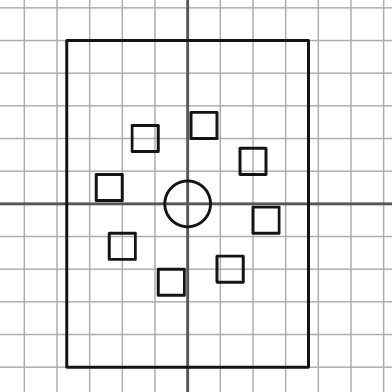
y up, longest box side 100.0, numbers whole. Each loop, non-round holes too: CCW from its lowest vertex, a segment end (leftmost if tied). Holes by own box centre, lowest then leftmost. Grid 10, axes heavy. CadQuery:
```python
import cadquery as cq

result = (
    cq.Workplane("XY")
    .moveTo(-37.0, -50.0)
    .lineTo(37.0, -50.0)
    .lineTo(37.0, 50.0)
    .lineTo(-37.0, 50.0)
    .close()
    .moveTo(-9.0, -28.0)
    .lineTo(-1.0, -28.0)
    .lineTo(-1.0, -20.0)
    .lineTo(-9.0, -20.0)
    .close()
    .moveTo(9.0, -24.0)
    .lineTo(17.0, -24.0)
    .lineTo(17.0, -16.0)
    .lineTo(9.0, -16.0)
    .close()
    .moveTo(-24.0, -17.0)
    .lineTo(-16.0, -17.0)
    .lineTo(-16.0, -9.0)
    .lineTo(-24.0, -9.0)
    .close()
    .moveTo(20.0, -9.0)
    .lineTo(28.0, -9.0)
    .lineTo(28.0, -1.0)
    .lineTo(20.0, -1.0)
    .close()
    .moveTo(0.0, 0.0)
    .circle(7.0)
    .moveTo(-28.0, 1.0)
    .lineTo(-20.0, 1.0)
    .lineTo(-20.0, 9.0)
    .lineTo(-28.0, 9.0)
    .close()
    .moveTo(16.0, 9.0)
    .lineTo(24.0, 9.0)
    .lineTo(24.0, 17.0)
    .lineTo(16.0, 17.0)
    .close()
    .moveTo(-17.0, 16.0)
    .lineTo(-9.0, 16.0)
    .lineTo(-9.0, 24.0)
    .lineTo(-17.0, 24.0)
    .close()
    .moveTo(1.0, 20.0)
    .lineTo(9.0, 20.0)
    .lineTo(9.0, 28.0)
    .lineTo(1.0, 28.0)
    .close()
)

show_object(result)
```